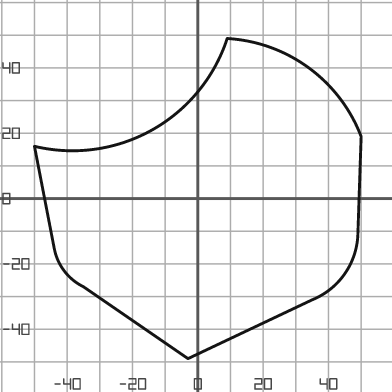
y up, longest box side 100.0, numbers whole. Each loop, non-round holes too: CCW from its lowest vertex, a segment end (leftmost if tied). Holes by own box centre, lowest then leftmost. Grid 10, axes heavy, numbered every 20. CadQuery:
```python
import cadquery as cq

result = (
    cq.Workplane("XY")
    .moveTo(-3.0, -49.0)
    .lineTo(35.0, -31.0)
    .threePointArc((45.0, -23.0), (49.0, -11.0))
    .lineTo(50.0, 19.0)
    .threePointArc((34.0, 40.0), (9.0, 49.0))
    .threePointArc((-14.0, 21.0), (-50.0, 16.0))
    .lineTo(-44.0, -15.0)
    .threePointArc((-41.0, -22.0), (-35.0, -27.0))
    .close()
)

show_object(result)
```